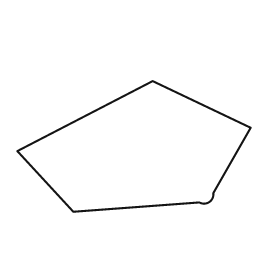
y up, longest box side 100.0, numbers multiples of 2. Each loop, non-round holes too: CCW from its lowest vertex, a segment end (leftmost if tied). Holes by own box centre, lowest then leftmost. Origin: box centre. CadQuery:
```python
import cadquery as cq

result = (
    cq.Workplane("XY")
    .moveTo(-26.0, -28.0)
    .lineTo(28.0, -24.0)
    .threePointArc((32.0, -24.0), (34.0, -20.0))
    .lineTo(50.0, 8.0)
    .lineTo(8.0, 28.0)
    .lineTo(-50.0, -2.0)
    .close()
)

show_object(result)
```